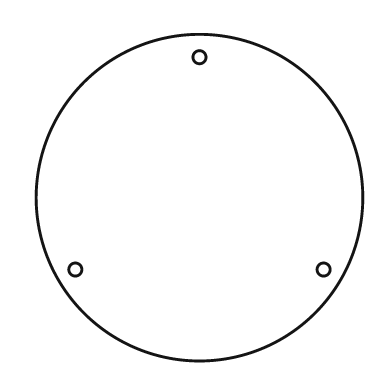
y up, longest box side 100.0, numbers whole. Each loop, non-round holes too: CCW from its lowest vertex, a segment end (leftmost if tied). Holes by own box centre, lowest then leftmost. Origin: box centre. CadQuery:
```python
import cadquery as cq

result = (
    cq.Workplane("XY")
    .moveTo(0.0, 0.0)
    .circle(50.0)
    .moveTo(-38.0, -22.0)
    .circle(2.0)
    .moveTo(38.0, -22.0)
    .circle(2.0)
    .moveTo(0.0, 43.0)
    .circle(2.0)
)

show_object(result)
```